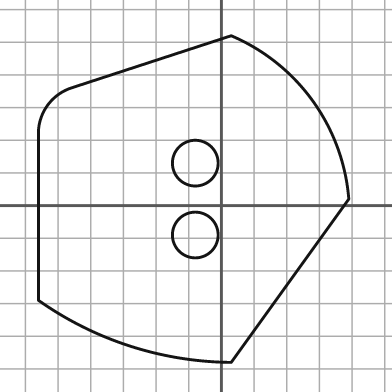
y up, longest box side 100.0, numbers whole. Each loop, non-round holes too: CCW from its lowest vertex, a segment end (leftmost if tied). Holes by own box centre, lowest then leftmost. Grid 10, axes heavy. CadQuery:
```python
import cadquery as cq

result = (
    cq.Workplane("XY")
    .moveTo(3.0, -48.0)
    .lineTo(39.0, 2.0)
    .threePointArc((28.0, 32.0), (3.0, 52.0))
    .lineTo(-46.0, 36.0)
    .threePointArc((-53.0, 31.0), (-56.0, 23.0))
    .lineTo(-56.0, -29.0)
    .threePointArc((-28.0, -43.0), (3.0, -48.0))
    .close()
    .moveTo(-8.0, -9.0)
    .circle(7.0)
    .moveTo(-8.0, 13.0)
    .circle(7.0)
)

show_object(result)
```